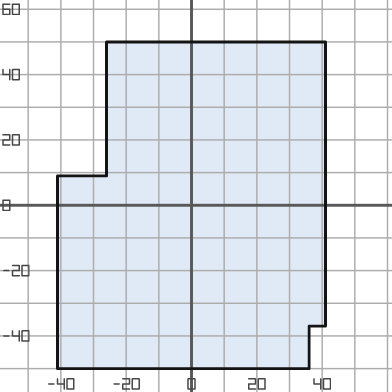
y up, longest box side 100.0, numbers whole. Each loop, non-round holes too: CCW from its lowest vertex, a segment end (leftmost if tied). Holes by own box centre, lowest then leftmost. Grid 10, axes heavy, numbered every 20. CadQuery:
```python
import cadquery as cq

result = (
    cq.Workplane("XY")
    .moveTo(-41.0, -50.0)
    .lineTo(36.0, -50.0)
    .lineTo(36.0, -37.0)
    .lineTo(41.0, -37.0)
    .lineTo(41.0, 50.0)
    .lineTo(-26.0, 50.0)
    .lineTo(-26.0, 9.0)
    .lineTo(-41.0, 9.0)
    .close()
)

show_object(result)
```